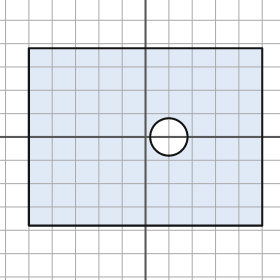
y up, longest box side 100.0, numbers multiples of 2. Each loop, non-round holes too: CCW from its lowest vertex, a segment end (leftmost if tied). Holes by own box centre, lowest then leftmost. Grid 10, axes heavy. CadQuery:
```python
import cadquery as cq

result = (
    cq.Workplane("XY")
    .moveTo(-50.0, -38.0)
    .lineTo(50.0, -38.0)
    .lineTo(50.0, 38.0)
    .lineTo(-50.0, 38.0)
    .close()
    .moveTo(10.0, 0.0)
    .circle(8.0)
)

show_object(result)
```